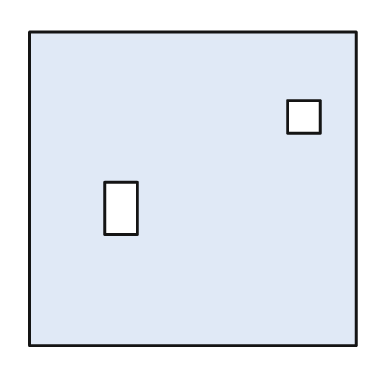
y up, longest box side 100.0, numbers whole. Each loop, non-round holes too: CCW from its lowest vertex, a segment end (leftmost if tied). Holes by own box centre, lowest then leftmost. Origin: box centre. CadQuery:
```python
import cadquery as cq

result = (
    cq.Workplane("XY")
    .moveTo(-50.0, -48.0)
    .lineTo(50.0, -48.0)
    .lineTo(50.0, 48.0)
    .lineTo(-50.0, 48.0)
    .close()
    .moveTo(-27.0, -14.0)
    .lineTo(-17.0, -14.0)
    .lineTo(-17.0, 2.0)
    .lineTo(-27.0, 2.0)
    .close()
    .moveTo(29.0, 17.0)
    .lineTo(39.0, 17.0)
    .lineTo(39.0, 27.0)
    .lineTo(29.0, 27.0)
    .close()
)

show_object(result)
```